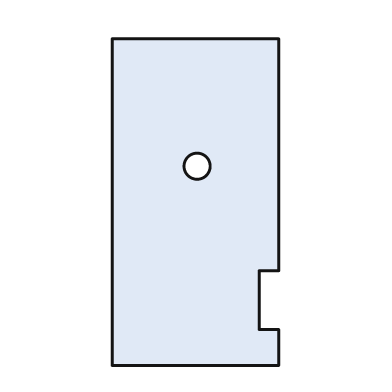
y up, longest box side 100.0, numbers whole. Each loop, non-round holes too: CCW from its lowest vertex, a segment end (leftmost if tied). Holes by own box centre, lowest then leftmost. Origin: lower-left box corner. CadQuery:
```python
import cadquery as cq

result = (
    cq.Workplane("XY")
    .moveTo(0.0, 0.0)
    .lineTo(51.0, 0.0)
    .lineTo(51.0, 11.0)
    .lineTo(45.0, 11.0)
    .lineTo(45.0, 29.0)
    .lineTo(51.0, 29.0)
    .lineTo(51.0, 100.0)
    .lineTo(0.0, 100.0)
    .close()
    .moveTo(26.0, 61.0)
    .circle(4.0)
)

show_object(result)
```